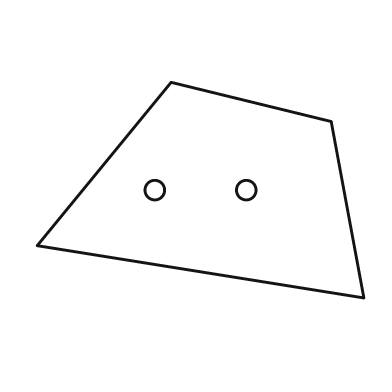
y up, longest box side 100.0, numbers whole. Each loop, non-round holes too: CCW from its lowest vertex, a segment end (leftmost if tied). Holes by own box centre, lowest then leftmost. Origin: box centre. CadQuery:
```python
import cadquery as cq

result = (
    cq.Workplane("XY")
    .moveTo(50.0, -33.0)
    .lineTo(40.0, 21.0)
    .lineTo(-9.0, 33.0)
    .lineTo(-50.0, -17.0)
    .close()
    .moveTo(-14.0, 0.0)
    .circle(3.0)
    .moveTo(14.0, 0.0)
    .circle(3.0)
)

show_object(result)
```